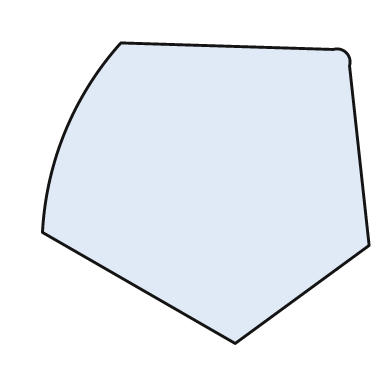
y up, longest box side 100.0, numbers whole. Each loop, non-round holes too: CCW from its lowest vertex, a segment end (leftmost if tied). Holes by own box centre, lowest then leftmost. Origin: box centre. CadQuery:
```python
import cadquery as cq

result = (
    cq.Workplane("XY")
    .moveTo(9.0, -46.0)
    .lineTo(50.0, -16.0)
    .lineTo(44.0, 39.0)
    .threePointArc((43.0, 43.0), (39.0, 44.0))
    .lineTo(-26.0, 46.0)
    .threePointArc((-43.0, 19.0), (-50.0, -12.0))
    .close()
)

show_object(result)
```